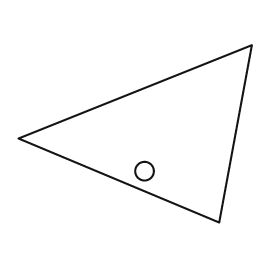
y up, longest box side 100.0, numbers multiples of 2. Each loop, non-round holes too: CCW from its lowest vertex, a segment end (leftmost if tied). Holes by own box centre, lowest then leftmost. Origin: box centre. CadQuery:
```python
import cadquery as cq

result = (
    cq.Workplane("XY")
    .moveTo(36.0, -38.0)
    .lineTo(50.0, 38.0)
    .lineTo(-50.0, -2.0)
    .close()
    .moveTo(4.0, -16.0)
    .circle(4.0)
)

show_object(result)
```